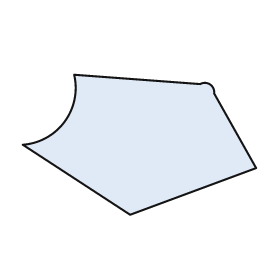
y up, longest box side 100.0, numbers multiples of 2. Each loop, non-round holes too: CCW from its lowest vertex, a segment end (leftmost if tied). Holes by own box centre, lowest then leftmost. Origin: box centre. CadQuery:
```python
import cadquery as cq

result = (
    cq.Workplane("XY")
    .moveTo(-4.0, -30.0)
    .lineTo(50.0, -10.0)
    .lineTo(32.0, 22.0)
    .threePointArc((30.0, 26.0), (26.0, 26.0))
    .lineTo(-28.0, 30.0)
    .threePointArc((-32.0, 10.0), (-50.0, 0.0))
    .close()
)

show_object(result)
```